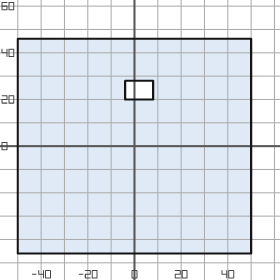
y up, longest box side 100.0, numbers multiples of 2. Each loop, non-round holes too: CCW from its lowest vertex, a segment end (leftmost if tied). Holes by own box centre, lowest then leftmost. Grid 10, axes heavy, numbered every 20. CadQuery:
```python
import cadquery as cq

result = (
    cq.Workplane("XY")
    .moveTo(-50.0, -46.0)
    .lineTo(50.0, -46.0)
    .lineTo(50.0, 46.0)
    .lineTo(-50.0, 46.0)
    .close()
    .moveTo(-4.0, 20.0)
    .lineTo(8.0, 20.0)
    .lineTo(8.0, 28.0)
    .lineTo(-4.0, 28.0)
    .close()
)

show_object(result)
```